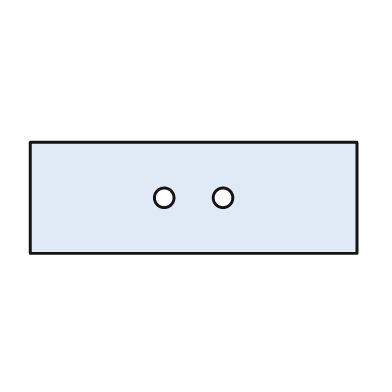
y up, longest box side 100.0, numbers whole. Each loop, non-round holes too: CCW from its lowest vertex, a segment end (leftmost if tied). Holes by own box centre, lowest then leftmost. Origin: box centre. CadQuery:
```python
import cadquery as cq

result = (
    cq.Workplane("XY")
    .moveTo(-50.0, -17.0)
    .lineTo(50.0, -17.0)
    .lineTo(50.0, 17.0)
    .lineTo(-50.0, 17.0)
    .close()
    .moveTo(-9.0, 0.0)
    .circle(3.0)
    .moveTo(9.0, 0.0)
    .circle(3.0)
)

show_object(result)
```